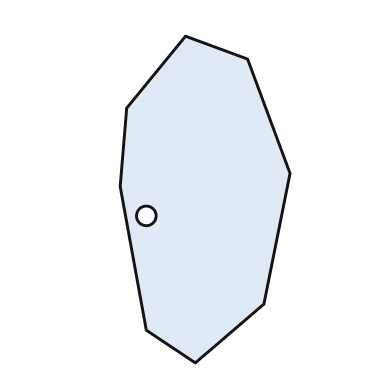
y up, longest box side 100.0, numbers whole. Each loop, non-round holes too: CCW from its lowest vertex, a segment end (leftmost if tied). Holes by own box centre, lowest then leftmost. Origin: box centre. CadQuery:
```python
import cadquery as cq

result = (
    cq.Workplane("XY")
    .moveTo(-3.0, -50.0)
    .lineTo(18.0, -32.0)
    .lineTo(26.0, 8.0)
    .lineTo(13.0, 43.0)
    .lineTo(-6.0, 50.0)
    .lineTo(-24.0, 28.0)
    .lineTo(-26.0, 4.0)
    .lineTo(-18.0, -40.0)
    .close()
    .moveTo(-18.0, -5.0)
    .circle(3.0)
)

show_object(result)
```